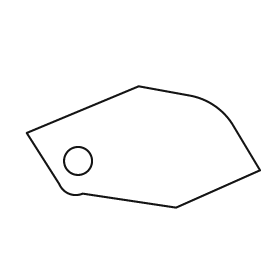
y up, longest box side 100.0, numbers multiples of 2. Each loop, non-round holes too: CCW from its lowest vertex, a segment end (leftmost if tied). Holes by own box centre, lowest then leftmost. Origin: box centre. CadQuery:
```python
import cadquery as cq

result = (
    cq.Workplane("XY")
    .moveTo(14.0, -26.0)
    .lineTo(50.0, -10.0)
    .lineTo(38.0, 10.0)
    .threePointArc((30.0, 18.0), (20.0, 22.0))
    .lineTo(-2.0, 26.0)
    .lineTo(-50.0, 6.0)
    .lineTo(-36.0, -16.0)
    .threePointArc((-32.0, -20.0), (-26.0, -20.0))
    .close()
    .moveTo(-28.0, -6.0)
    .circle(6.0)
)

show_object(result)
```